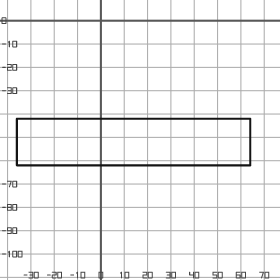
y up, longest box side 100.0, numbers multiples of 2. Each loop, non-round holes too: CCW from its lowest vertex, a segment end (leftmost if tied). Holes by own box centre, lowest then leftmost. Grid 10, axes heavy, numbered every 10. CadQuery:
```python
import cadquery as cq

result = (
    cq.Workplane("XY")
    .moveTo(-36.0, -62.0)
    .lineTo(64.0, -62.0)
    .lineTo(64.0, -42.0)
    .lineTo(-36.0, -42.0)
    .close()
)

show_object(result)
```